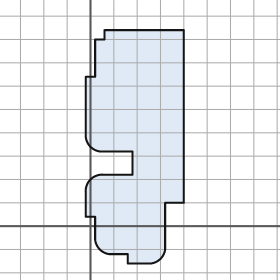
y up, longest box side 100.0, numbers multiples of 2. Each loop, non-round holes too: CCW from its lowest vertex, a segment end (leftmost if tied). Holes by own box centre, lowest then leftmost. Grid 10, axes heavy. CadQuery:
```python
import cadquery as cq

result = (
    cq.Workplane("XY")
    .moveTo(16.0, -16.0)
    .lineTo(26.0, -16.0)
    .threePointArc((30.0, -14.0), (32.0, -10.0))
    .lineTo(32.0, 10.0)
    .lineTo(40.0, 10.0)
    .lineTo(40.0, 84.0)
    .lineTo(6.0, 84.0)
    .lineTo(6.0, 80.0)
    .lineTo(2.0, 80.0)
    .lineTo(2.0, 64.0)
    .lineTo(-2.0, 64.0)
    .lineTo(-2.0, 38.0)
    .threePointArc((0.0, 34.0), (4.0, 32.0))
    .lineTo(18.0, 32.0)
    .lineTo(18.0, 22.0)
    .lineTo(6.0, 22.0)
    .threePointArc((0.0, 20.0), (-2.0, 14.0))
    .lineTo(-2.0, 4.0)
    .lineTo(2.0, 4.0)
    .lineTo(2.0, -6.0)
    .threePointArc((4.0, -10.0), (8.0, -12.0))
    .lineTo(16.0, -12.0)
    .close()
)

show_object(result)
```